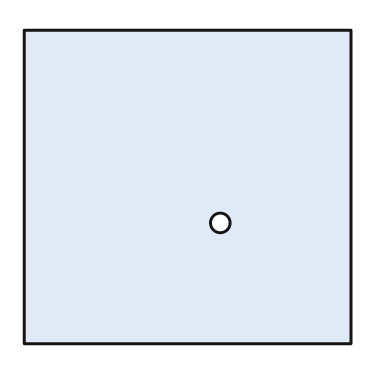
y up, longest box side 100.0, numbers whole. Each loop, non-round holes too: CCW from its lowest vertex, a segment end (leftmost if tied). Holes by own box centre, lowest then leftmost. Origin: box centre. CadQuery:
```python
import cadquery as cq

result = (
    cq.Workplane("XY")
    .moveTo(-50.0, -48.0)
    .lineTo(50.0, -48.0)
    .lineTo(50.0, 48.0)
    .lineTo(-50.0, 48.0)
    .close()
    .moveTo(10.0, -11.0)
    .circle(3.0)
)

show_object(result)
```